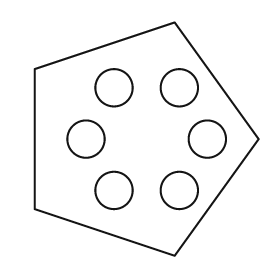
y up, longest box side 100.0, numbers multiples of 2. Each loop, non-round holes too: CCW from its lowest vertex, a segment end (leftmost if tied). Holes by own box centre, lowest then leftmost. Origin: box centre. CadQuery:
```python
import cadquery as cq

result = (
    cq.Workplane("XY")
    .moveTo(12.0, -50.0)
    .lineTo(48.0, 0.0)
    .lineTo(12.0, 50.0)
    .lineTo(-48.0, 30.0)
    .lineTo(-48.0, -30.0)
    .close()
    .moveTo(-14.0, -22.0)
    .circle(8.0)
    .moveTo(14.0, -22.0)
    .circle(8.0)
    .moveTo(-26.0, 0.0)
    .circle(8.0)
    .moveTo(26.0, 0.0)
    .circle(8.0)
    .moveTo(-14.0, 22.0)
    .circle(8.0)
    .moveTo(14.0, 22.0)
    .circle(8.0)
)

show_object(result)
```